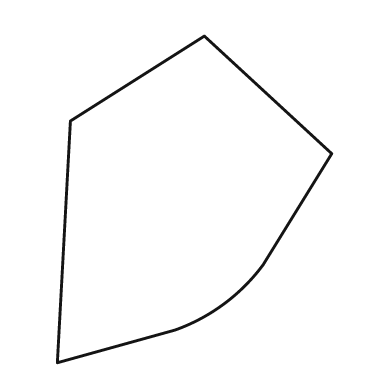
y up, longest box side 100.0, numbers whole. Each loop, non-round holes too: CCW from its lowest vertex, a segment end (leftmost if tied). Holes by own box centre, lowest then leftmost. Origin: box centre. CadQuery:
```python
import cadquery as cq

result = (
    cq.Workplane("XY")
    .moveTo(-42.0, -50.0)
    .lineTo(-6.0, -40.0)
    .threePointArc((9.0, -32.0), (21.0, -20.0))
    .lineTo(42.0, 14.0)
    .lineTo(3.0, 50.0)
    .lineTo(-38.0, 24.0)
    .close()
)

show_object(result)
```